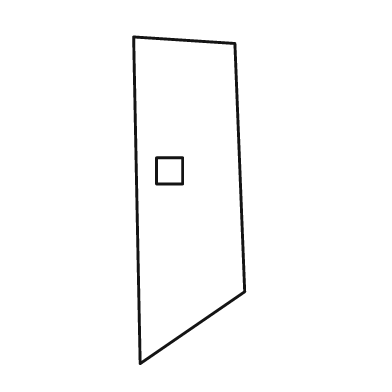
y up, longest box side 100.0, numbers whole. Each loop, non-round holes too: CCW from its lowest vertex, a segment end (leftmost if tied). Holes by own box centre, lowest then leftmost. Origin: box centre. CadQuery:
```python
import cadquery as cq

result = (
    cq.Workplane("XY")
    .moveTo(-15.0, -50.0)
    .lineTo(17.0, -28.0)
    .lineTo(14.0, 48.0)
    .lineTo(-17.0, 50.0)
    .close()
    .moveTo(-10.0, 5.0)
    .lineTo(-2.0, 5.0)
    .lineTo(-2.0, 13.0)
    .lineTo(-10.0, 13.0)
    .close()
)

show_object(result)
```